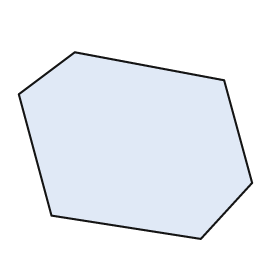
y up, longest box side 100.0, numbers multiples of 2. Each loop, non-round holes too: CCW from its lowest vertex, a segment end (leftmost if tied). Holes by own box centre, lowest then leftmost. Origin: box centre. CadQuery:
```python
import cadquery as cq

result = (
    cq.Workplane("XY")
    .moveTo(28.0, -40.0)
    .lineTo(50.0, -16.0)
    .lineTo(38.0, 28.0)
    .lineTo(-26.0, 40.0)
    .lineTo(-50.0, 22.0)
    .lineTo(-36.0, -30.0)
    .close()
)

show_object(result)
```